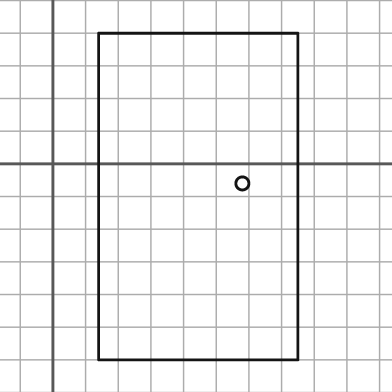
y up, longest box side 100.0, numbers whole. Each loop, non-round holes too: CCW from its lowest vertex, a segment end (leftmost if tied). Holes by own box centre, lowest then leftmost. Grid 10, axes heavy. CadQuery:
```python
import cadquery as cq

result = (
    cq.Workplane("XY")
    .moveTo(14.0, -60.0)
    .lineTo(75.0, -60.0)
    .lineTo(75.0, 40.0)
    .lineTo(14.0, 40.0)
    .close()
    .moveTo(58.0, -6.0)
    .circle(2.0)
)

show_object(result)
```